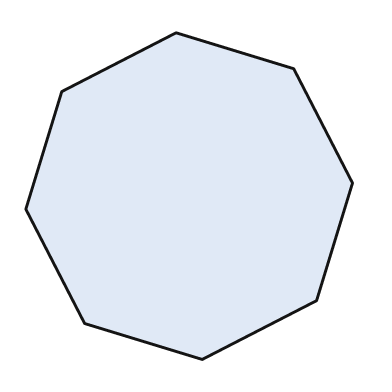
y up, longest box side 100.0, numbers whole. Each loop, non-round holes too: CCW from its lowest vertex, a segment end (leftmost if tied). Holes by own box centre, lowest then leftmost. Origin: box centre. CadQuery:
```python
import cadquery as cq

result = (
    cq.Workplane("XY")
    .moveTo(4.0, -50.0)
    .lineTo(39.0, -32.0)
    .lineTo(50.0, 4.0)
    .lineTo(32.0, 39.0)
    .lineTo(-4.0, 50.0)
    .lineTo(-39.0, 32.0)
    .lineTo(-50.0, -4.0)
    .lineTo(-32.0, -39.0)
    .close()
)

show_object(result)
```